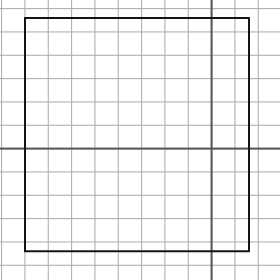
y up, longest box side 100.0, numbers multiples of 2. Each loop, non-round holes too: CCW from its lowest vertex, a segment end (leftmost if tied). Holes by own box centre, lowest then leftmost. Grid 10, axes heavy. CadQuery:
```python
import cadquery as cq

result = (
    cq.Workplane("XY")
    .moveTo(-80.0, -44.0)
    .lineTo(16.0, -44.0)
    .lineTo(16.0, 56.0)
    .lineTo(-80.0, 56.0)
    .close()
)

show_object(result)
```